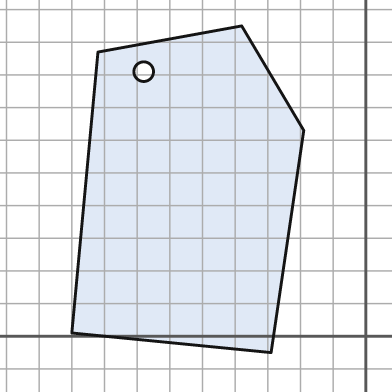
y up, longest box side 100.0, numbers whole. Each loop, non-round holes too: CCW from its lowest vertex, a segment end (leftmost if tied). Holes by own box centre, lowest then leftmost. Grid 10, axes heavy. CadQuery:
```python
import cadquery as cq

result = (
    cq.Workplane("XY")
    .moveTo(-29.0, -5.0)
    .lineTo(-19.0, 63.0)
    .lineTo(-38.0, 95.0)
    .lineTo(-82.0, 87.0)
    .lineTo(-90.0, 1.0)
    .close()
    .moveTo(-68.0, 81.0)
    .circle(3.0)
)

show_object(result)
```